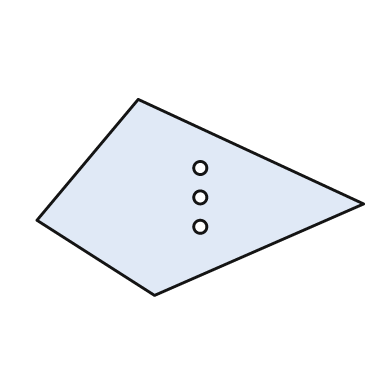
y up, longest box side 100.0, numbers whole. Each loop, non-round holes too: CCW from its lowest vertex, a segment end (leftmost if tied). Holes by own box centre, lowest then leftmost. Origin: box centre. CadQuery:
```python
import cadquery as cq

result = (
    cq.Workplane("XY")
    .moveTo(-14.0, -30.0)
    .lineTo(50.0, -2.0)
    .lineTo(-19.0, 30.0)
    .lineTo(-50.0, -7.0)
    .close()
    .moveTo(0.0, -9.0)
    .circle(2.0)
    .moveTo(0.0, 0.0)
    .circle(2.0)
    .moveTo(0.0, 9.0)
    .circle(2.0)
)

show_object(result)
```